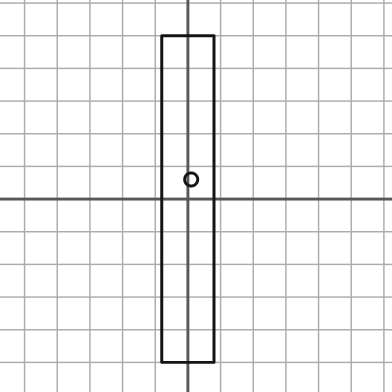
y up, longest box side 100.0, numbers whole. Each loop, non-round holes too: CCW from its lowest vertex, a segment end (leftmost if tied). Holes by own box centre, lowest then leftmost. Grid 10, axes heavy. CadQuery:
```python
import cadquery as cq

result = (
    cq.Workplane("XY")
    .moveTo(-8.0, -50.0)
    .lineTo(8.0, -50.0)
    .lineTo(8.0, 50.0)
    .lineTo(-8.0, 50.0)
    .close()
    .moveTo(1.0, 6.0)
    .circle(2.0)
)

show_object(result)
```